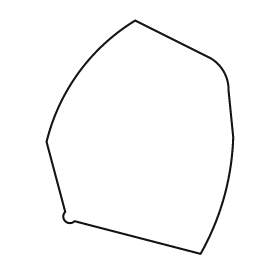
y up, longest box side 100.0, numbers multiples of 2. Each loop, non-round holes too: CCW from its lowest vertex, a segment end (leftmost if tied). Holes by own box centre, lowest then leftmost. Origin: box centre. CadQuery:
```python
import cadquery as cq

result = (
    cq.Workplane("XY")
    .moveTo(26.0, -50.0)
    .threePointArc((36.0, -26.0), (40.0, 0.0))
    .lineTo(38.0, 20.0)
    .threePointArc((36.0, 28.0), (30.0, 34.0))
    .lineTo(-2.0, 50.0)
    .threePointArc((-26.0, 28.0), (-40.0, -2.0))
    .lineTo(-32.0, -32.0)
    .threePointArc((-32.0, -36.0), (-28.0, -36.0))
    .close()
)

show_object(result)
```